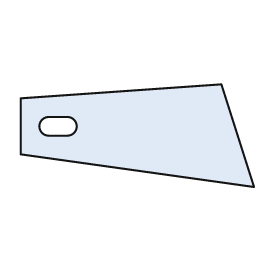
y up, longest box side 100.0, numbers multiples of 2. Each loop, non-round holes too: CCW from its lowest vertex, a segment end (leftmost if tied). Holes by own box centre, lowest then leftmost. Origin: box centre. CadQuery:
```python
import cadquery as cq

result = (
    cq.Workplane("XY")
    .moveTo(50.0, -22.0)
    .lineTo(36.0, 22.0)
    .lineTo(-50.0, 16.0)
    .lineTo(-50.0, -8.0)
    .close()
    .moveTo(-38.0, 0.0)
    .lineTo(-30.0, 0.0)
    .threePointArc((-26.0, 4.0), (-30.0, 8.0))
    .lineTo(-38.0, 8.0)
    .threePointArc((-42.0, 4.0), (-38.0, 0.0))
    .close()
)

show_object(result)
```